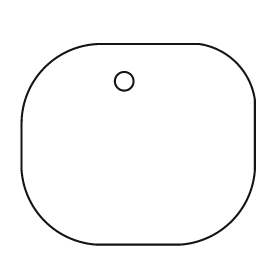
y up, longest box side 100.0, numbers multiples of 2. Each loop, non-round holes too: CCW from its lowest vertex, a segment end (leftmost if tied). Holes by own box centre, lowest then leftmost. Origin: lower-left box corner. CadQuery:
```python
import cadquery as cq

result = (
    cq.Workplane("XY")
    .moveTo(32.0, 0.0)
    .lineTo(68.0, 0.0)
    .threePointArc((90.0, 10.0), (100.0, 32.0))
    .lineTo(100.0, 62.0)
    .threePointArc((92.0, 78.0), (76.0, 86.0))
    .lineTo(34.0, 86.0)
    .threePointArc((10.0, 76.0), (0.0, 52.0))
    .lineTo(0.0, 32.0)
    .threePointArc((10.0, 10.0), (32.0, 0.0))
    .close()
    .moveTo(44.0, 70.0)
    .circle(4.0)
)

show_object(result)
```